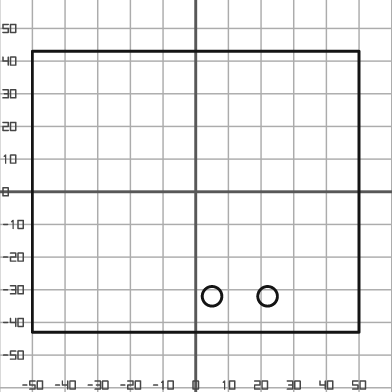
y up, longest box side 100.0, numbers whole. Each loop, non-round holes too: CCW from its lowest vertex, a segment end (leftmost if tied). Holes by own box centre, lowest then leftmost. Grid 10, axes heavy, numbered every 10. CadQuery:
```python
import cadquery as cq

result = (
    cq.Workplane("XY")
    .moveTo(-50.0, -43.0)
    .lineTo(50.0, -43.0)
    .lineTo(50.0, 43.0)
    .lineTo(-50.0, 43.0)
    .close()
    .moveTo(5.0, -32.0)
    .circle(3.0)
    .moveTo(22.0, -32.0)
    .circle(3.0)
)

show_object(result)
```